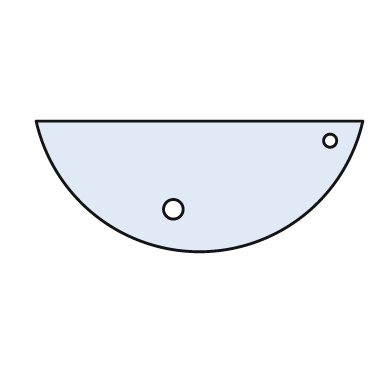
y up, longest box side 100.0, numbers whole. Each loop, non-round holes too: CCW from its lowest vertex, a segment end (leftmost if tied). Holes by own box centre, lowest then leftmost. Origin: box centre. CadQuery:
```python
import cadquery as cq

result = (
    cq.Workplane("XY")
    .moveTo(-50.0, 20.0)
    .threePointArc((0.0, -20.0), (50.0, 20.0))
    .close()
    .moveTo(-8.0, -7.0)
    .circle(3.0)
    .moveTo(40.0, 14.0)
    .circle(2.0)
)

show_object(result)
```